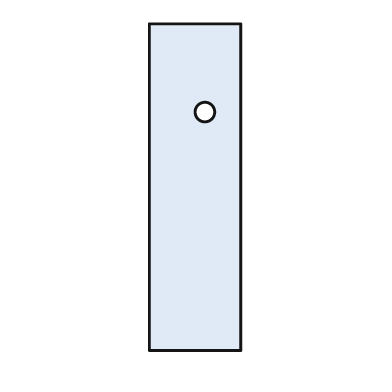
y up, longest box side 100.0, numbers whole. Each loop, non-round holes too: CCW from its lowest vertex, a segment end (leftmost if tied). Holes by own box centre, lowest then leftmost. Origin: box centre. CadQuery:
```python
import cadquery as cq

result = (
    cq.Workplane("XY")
    .moveTo(-14.0, -50.0)
    .lineTo(14.0, -50.0)
    .lineTo(14.0, 50.0)
    .lineTo(-14.0, 50.0)
    .close()
    .moveTo(3.0, 23.0)
    .circle(3.0)
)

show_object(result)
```